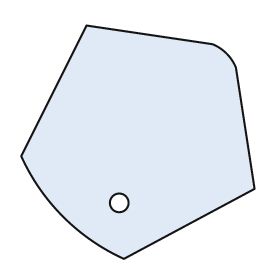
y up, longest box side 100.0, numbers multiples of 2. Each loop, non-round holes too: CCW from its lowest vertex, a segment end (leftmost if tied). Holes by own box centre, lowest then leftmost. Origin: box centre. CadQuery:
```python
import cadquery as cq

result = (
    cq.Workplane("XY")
    .moveTo(-6.0, -50.0)
    .lineTo(50.0, -20.0)
    .lineTo(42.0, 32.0)
    .threePointArc((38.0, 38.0), (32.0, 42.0))
    .lineTo(-22.0, 50.0)
    .lineTo(-50.0, -6.0)
    .threePointArc((-32.0, -32.0), (-6.0, -50.0))
    .close()
    .moveTo(-8.0, -26.0)
    .circle(4.0)
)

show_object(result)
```